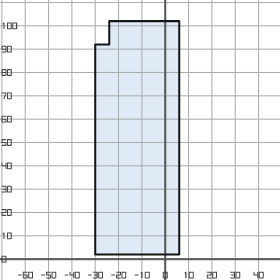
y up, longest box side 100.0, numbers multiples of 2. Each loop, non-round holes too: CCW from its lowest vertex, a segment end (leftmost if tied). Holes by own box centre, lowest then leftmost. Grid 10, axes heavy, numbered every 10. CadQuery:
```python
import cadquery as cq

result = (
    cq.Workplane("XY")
    .moveTo(-30.0, 2.0)
    .lineTo(6.0, 2.0)
    .lineTo(6.0, 102.0)
    .lineTo(-24.0, 102.0)
    .lineTo(-24.0, 92.0)
    .lineTo(-30.0, 92.0)
    .close()
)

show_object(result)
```